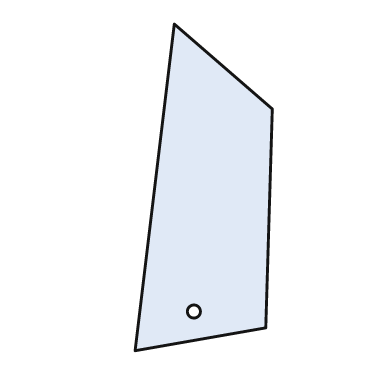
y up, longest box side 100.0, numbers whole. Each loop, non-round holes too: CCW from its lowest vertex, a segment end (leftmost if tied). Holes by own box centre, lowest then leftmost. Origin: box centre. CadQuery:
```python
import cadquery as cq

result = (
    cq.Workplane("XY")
    .moveTo(-21.0, -50.0)
    .lineTo(19.0, -43.0)
    .lineTo(21.0, 24.0)
    .lineTo(-9.0, 50.0)
    .close()
    .moveTo(-3.0, -38.0)
    .circle(2.0)
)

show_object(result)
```